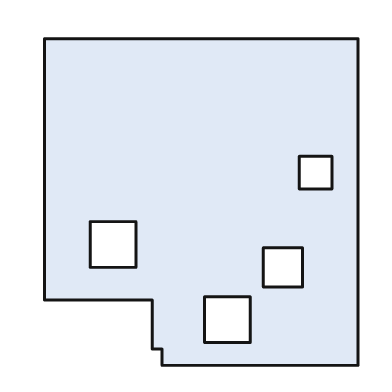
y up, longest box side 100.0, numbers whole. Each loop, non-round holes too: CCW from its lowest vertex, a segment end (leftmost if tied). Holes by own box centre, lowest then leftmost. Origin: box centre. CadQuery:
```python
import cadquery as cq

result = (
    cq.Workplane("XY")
    .moveTo(-12.0, -50.0)
    .lineTo(48.0, -50.0)
    .lineTo(48.0, 50.0)
    .lineTo(-48.0, 50.0)
    .lineTo(-48.0, -30.0)
    .lineTo(-15.0, -30.0)
    .lineTo(-15.0, -45.0)
    .lineTo(-12.0, -45.0)
    .close()
    .moveTo(1.0, -43.0)
    .lineTo(15.0, -43.0)
    .lineTo(15.0, -29.0)
    .lineTo(1.0, -29.0)
    .close()
    .moveTo(19.0, -26.0)
    .lineTo(31.0, -26.0)
    .lineTo(31.0, -14.0)
    .lineTo(19.0, -14.0)
    .close()
    .moveTo(-34.0, -20.0)
    .lineTo(-20.0, -20.0)
    .lineTo(-20.0, -6.0)
    .lineTo(-34.0, -6.0)
    .close()
    .moveTo(30.0, 4.0)
    .lineTo(40.0, 4.0)
    .lineTo(40.0, 14.0)
    .lineTo(30.0, 14.0)
    .close()
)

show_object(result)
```